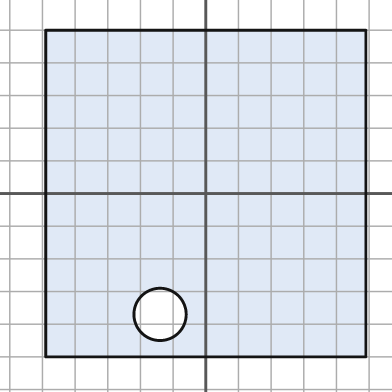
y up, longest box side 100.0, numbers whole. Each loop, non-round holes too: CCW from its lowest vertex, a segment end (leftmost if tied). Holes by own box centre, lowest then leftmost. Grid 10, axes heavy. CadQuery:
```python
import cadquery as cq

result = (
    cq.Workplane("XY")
    .moveTo(-49.0, -50.0)
    .lineTo(49.0, -50.0)
    .lineTo(49.0, 50.0)
    .lineTo(-49.0, 50.0)
    .close()
    .moveTo(-14.0, -37.0)
    .circle(8.0)
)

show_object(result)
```